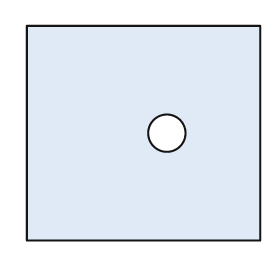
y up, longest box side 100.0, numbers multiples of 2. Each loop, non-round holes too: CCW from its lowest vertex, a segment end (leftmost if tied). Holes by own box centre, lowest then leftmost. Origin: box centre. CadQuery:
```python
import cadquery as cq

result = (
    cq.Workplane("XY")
    .moveTo(-50.0, -46.0)
    .lineTo(50.0, -46.0)
    .lineTo(50.0, 46.0)
    .lineTo(-50.0, 46.0)
    .close()
    .moveTo(10.0, 0.0)
    .circle(8.0)
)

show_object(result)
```